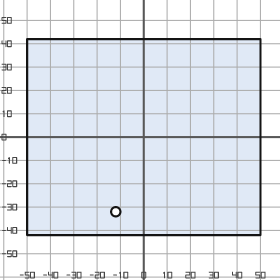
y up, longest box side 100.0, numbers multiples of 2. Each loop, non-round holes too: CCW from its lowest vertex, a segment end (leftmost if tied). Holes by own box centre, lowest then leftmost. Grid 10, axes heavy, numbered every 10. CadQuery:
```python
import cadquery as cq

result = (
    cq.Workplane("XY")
    .moveTo(-50.0, -42.0)
    .lineTo(50.0, -42.0)
    .lineTo(50.0, 42.0)
    .lineTo(-50.0, 42.0)
    .close()
    .moveTo(-12.0, -32.0)
    .circle(2.0)
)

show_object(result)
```